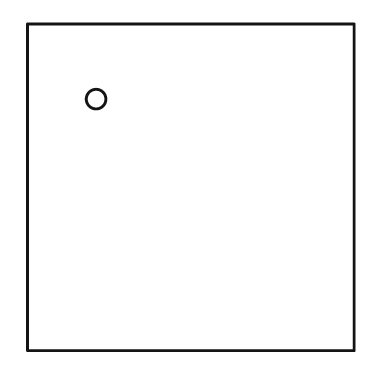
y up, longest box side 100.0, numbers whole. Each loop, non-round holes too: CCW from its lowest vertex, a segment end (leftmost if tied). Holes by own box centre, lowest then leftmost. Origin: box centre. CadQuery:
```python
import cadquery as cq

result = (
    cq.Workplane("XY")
    .moveTo(-50.0, -50.0)
    .lineTo(50.0, -50.0)
    .lineTo(50.0, 50.0)
    .lineTo(-50.0, 50.0)
    .close()
    .moveTo(-29.0, 27.0)
    .circle(3.0)
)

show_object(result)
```